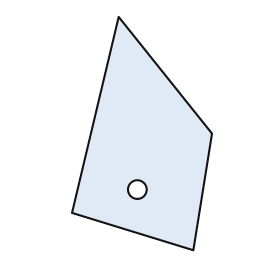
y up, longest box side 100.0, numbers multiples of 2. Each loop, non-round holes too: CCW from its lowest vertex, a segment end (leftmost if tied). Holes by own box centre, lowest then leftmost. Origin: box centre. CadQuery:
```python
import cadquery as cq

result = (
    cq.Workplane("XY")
    .moveTo(22.0, -50.0)
    .lineTo(30.0, 0.0)
    .lineTo(-10.0, 50.0)
    .lineTo(-30.0, -34.0)
    .close()
    .moveTo(-2.0, -24.0)
    .circle(4.0)
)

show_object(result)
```